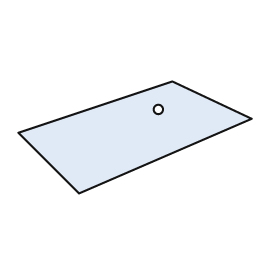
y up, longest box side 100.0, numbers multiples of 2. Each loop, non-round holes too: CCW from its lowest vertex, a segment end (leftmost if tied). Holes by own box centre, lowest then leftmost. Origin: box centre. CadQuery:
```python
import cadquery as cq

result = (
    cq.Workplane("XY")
    .moveTo(-24.0, -24.0)
    .lineTo(50.0, 8.0)
    .lineTo(16.0, 24.0)
    .lineTo(-50.0, 2.0)
    .close()
    .moveTo(10.0, 12.0)
    .circle(2.0)
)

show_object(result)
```